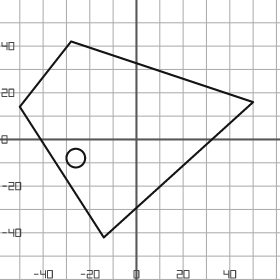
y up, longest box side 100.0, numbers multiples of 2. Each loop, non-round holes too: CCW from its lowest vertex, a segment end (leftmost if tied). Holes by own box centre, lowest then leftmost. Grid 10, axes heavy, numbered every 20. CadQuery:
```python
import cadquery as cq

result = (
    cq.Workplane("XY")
    .moveTo(-14.0, -42.0)
    .lineTo(50.0, 16.0)
    .lineTo(-28.0, 42.0)
    .lineTo(-50.0, 14.0)
    .close()
    .moveTo(-26.0, -8.0)
    .circle(4.0)
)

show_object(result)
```